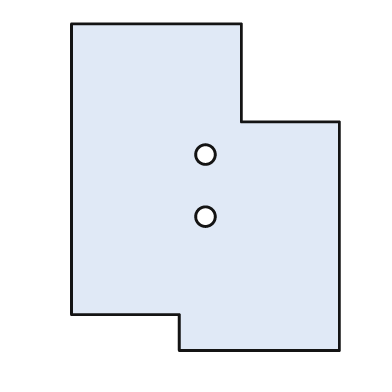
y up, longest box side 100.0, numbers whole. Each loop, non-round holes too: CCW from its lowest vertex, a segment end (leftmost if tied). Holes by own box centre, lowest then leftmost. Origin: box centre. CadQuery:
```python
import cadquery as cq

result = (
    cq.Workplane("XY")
    .moveTo(-8.0, -50.0)
    .lineTo(41.0, -50.0)
    .lineTo(41.0, 20.0)
    .lineTo(11.0, 20.0)
    .lineTo(11.0, 50.0)
    .lineTo(-41.0, 50.0)
    .lineTo(-41.0, -39.0)
    .lineTo(-8.0, -39.0)
    .close()
    .moveTo(0.0, -9.0)
    .circle(3.0)
    .moveTo(0.0, 10.0)
    .circle(3.0)
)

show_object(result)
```